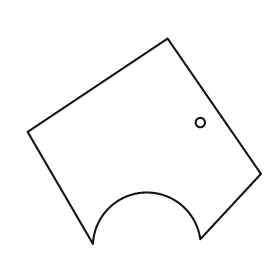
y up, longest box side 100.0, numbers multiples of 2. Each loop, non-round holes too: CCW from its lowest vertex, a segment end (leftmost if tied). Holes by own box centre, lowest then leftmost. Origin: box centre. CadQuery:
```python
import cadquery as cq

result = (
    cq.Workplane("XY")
    .moveTo(-22.0, -44.0)
    .threePointArc((0.0, -22.0), (24.0, -42.0))
    .lineTo(50.0, -14.0)
    .lineTo(10.0, 44.0)
    .lineTo(-50.0, 4.0)
    .close()
    .moveTo(24.0, 8.0)
    .circle(2.0)
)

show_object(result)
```